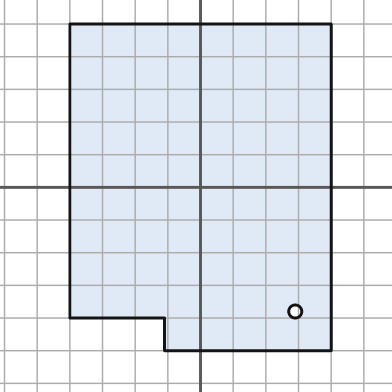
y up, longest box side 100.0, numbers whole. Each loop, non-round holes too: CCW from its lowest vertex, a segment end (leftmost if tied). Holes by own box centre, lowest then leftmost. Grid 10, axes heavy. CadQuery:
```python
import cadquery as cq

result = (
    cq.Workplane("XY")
    .moveTo(-11.0, -50.0)
    .lineTo(40.0, -50.0)
    .lineTo(40.0, 50.0)
    .lineTo(-40.0, 50.0)
    .lineTo(-40.0, -40.0)
    .lineTo(-11.0, -40.0)
    .close()
    .moveTo(29.0, -38.0)
    .circle(2.0)
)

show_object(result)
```